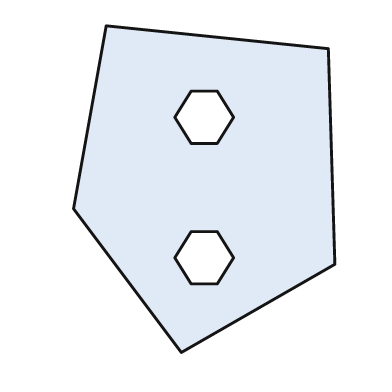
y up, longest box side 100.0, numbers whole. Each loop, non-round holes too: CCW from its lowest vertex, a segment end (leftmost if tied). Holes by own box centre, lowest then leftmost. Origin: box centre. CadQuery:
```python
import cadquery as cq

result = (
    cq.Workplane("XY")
    .moveTo(-7.0, -50.0)
    .lineTo(40.0, -23.0)
    .lineTo(38.0, 43.0)
    .lineTo(-30.0, 50.0)
    .lineTo(-40.0, -6.0)
    .close()
    .moveTo(-4.0, -29.0)
    .lineTo(4.0, -29.0)
    .lineTo(9.0, -21.0)
    .lineTo(4.0, -13.0)
    .lineTo(-4.0, -13.0)
    .lineTo(-9.0, -21.0)
    .close()
    .moveTo(-4.0, 14.0)
    .lineTo(4.0, 14.0)
    .lineTo(9.0, 22.0)
    .lineTo(4.0, 30.0)
    .lineTo(-4.0, 30.0)
    .lineTo(-9.0, 22.0)
    .close()
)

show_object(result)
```